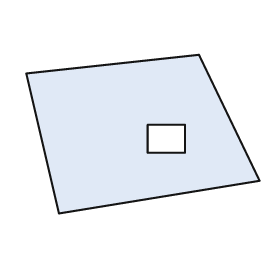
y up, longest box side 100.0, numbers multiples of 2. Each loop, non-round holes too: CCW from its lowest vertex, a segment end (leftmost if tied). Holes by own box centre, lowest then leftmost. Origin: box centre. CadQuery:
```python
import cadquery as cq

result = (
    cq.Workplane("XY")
    .moveTo(-36.0, -34.0)
    .lineTo(50.0, -20.0)
    .lineTo(24.0, 34.0)
    .lineTo(-50.0, 26.0)
    .close()
    .moveTo(2.0, -8.0)
    .lineTo(18.0, -8.0)
    .lineTo(18.0, 4.0)
    .lineTo(2.0, 4.0)
    .close()
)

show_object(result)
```